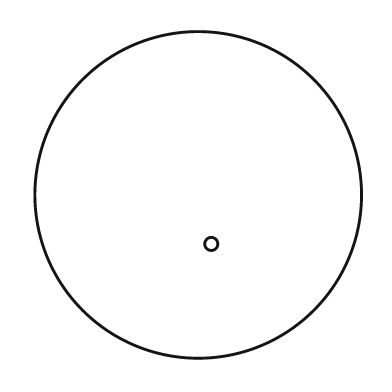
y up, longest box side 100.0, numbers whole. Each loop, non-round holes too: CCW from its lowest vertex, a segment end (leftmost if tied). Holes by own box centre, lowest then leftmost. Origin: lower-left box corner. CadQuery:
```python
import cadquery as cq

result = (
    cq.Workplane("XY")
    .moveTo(50.0, 50.0)
    .circle(50.0)
    .moveTo(54.0, 35.0)
    .circle(2.0)
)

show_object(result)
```